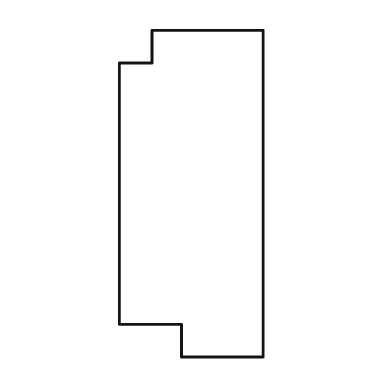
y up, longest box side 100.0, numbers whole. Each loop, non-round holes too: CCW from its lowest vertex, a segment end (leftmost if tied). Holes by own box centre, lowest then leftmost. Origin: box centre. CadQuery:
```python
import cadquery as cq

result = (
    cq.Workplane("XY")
    .moveTo(-3.0, -50.0)
    .lineTo(22.0, -50.0)
    .lineTo(22.0, 50.0)
    .lineTo(-12.0, 50.0)
    .lineTo(-12.0, 40.0)
    .lineTo(-22.0, 40.0)
    .lineTo(-22.0, -40.0)
    .lineTo(-3.0, -40.0)
    .close()
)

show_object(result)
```